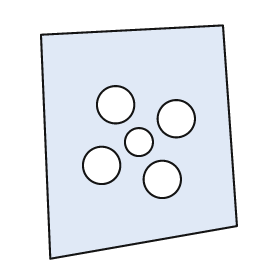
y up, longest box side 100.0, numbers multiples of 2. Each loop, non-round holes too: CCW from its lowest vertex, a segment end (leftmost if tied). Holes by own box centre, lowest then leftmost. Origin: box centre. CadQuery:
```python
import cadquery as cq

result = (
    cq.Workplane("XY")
    .moveTo(-38.0, -50.0)
    .lineTo(42.0, -36.0)
    .lineTo(36.0, 50.0)
    .lineTo(-42.0, 46.0)
    .close()
    .moveTo(10.0, -16.0)
    .circle(8.0)
    .moveTo(-16.0, -10.0)
    .circle(8.0)
    .moveTo(0.0, 0.0)
    .circle(6.0)
    .moveTo(16.0, 10.0)
    .circle(8.0)
    .moveTo(-10.0, 16.0)
    .circle(8.0)
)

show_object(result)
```